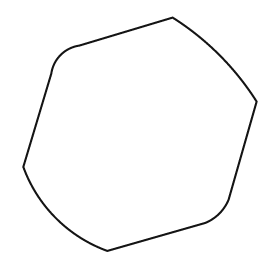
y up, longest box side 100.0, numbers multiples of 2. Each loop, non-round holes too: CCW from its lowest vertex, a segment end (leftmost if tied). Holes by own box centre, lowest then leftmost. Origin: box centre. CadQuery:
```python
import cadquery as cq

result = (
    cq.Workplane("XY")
    .moveTo(-14.0, -50.0)
    .lineTo(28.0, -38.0)
    .threePointArc((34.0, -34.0), (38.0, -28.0))
    .lineTo(50.0, 14.0)
    .threePointArc((34.0, 34.0), (14.0, 50.0))
    .lineTo(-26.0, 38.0)
    .threePointArc((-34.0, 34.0), (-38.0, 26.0))
    .lineTo(-50.0, -14.0)
    .threePointArc((-36.0, -36.0), (-14.0, -50.0))
    .close()
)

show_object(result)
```